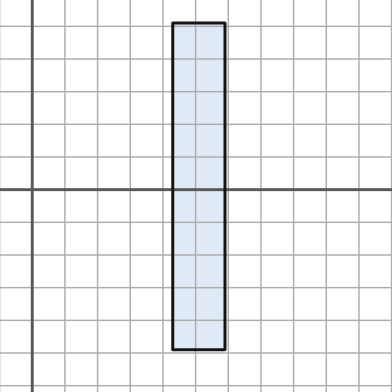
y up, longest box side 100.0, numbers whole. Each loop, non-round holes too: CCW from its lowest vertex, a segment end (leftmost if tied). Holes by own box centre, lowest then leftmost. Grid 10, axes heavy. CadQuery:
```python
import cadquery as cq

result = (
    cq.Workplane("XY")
    .moveTo(43.0, -49.0)
    .lineTo(59.0, -49.0)
    .lineTo(59.0, 51.0)
    .lineTo(43.0, 51.0)
    .close()
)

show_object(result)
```